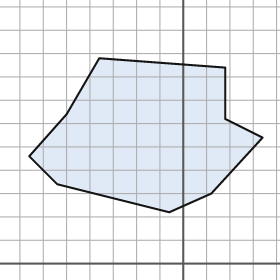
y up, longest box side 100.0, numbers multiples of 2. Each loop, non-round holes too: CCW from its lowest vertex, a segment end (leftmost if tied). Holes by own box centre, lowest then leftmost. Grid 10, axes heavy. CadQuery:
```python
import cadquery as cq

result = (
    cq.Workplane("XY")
    .moveTo(-6.0, 22.0)
    .lineTo(12.0, 30.0)
    .lineTo(34.0, 54.0)
    .lineTo(18.0, 62.0)
    .lineTo(18.0, 84.0)
    .lineTo(-36.0, 88.0)
    .lineTo(-50.0, 64.0)
    .lineTo(-66.0, 46.0)
    .lineTo(-54.0, 34.0)
    .close()
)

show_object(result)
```